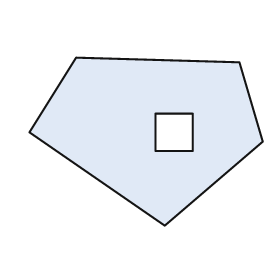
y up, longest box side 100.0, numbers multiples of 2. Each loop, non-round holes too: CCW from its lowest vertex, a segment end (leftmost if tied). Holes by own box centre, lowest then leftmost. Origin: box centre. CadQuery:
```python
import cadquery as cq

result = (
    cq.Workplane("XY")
    .moveTo(8.0, -36.0)
    .lineTo(50.0, 0.0)
    .lineTo(40.0, 34.0)
    .lineTo(-30.0, 36.0)
    .lineTo(-50.0, 4.0)
    .close()
    .moveTo(4.0, -4.0)
    .lineTo(20.0, -4.0)
    .lineTo(20.0, 12.0)
    .lineTo(4.0, 12.0)
    .close()
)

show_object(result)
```